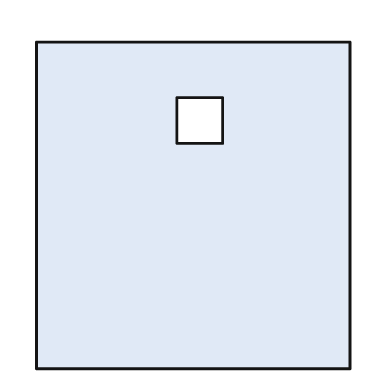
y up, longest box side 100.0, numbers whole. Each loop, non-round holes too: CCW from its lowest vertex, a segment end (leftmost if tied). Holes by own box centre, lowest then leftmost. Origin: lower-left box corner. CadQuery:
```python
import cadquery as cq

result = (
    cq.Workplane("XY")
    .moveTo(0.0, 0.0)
    .lineTo(96.0, 0.0)
    .lineTo(96.0, 100.0)
    .lineTo(0.0, 100.0)
    .close()
    .moveTo(43.0, 69.0)
    .lineTo(57.0, 69.0)
    .lineTo(57.0, 83.0)
    .lineTo(43.0, 83.0)
    .close()
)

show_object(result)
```